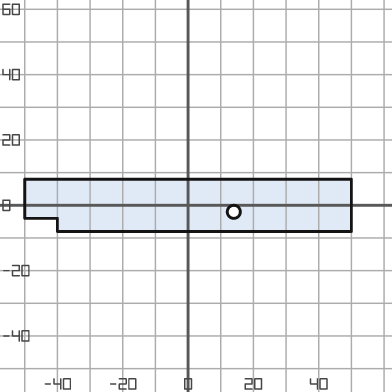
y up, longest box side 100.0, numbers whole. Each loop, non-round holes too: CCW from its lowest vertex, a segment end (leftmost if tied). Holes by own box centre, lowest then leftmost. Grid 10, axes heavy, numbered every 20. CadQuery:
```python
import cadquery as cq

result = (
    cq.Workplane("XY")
    .moveTo(-40.0, -8.0)
    .lineTo(50.0, -8.0)
    .lineTo(50.0, 8.0)
    .lineTo(-50.0, 8.0)
    .lineTo(-50.0, -4.0)
    .lineTo(-40.0, -4.0)
    .close()
    .moveTo(14.0, -2.0)
    .circle(2.0)
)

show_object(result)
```